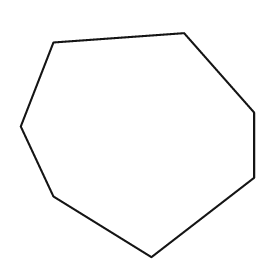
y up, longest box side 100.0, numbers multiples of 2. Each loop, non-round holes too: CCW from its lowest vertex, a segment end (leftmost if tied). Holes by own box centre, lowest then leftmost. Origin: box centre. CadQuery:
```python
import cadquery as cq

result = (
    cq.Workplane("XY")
    .moveTo(6.0, -48.0)
    .lineTo(50.0, -14.0)
    .lineTo(50.0, 14.0)
    .lineTo(20.0, 48.0)
    .lineTo(-36.0, 44.0)
    .lineTo(-50.0, 8.0)
    .lineTo(-36.0, -22.0)
    .close()
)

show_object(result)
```